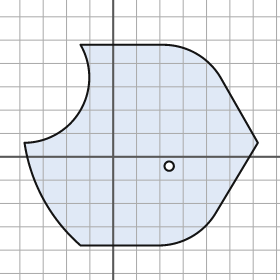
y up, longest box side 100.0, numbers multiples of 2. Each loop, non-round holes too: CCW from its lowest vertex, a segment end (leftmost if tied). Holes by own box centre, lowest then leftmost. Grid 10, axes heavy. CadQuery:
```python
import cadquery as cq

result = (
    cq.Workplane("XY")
    .moveTo(-14.0, -38.0)
    .lineTo(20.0, -38.0)
    .threePointArc((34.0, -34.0), (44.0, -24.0))
    .lineTo(62.0, 6.0)
    .lineTo(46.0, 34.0)
    .threePointArc((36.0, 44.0), (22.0, 48.0))
    .lineTo(-14.0, 48.0)
    .threePointArc((-14.0, 20.0), (-38.0, 6.0))
    .threePointArc((-30.0, -18.0), (-14.0, -38.0))
    .close()
    .moveTo(24.0, -4.0)
    .circle(2.0)
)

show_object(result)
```